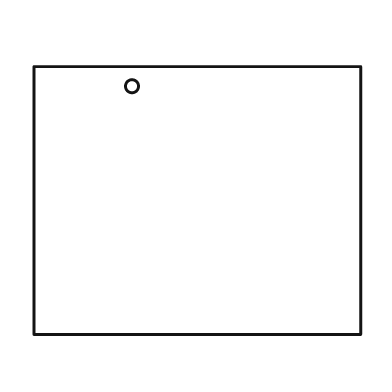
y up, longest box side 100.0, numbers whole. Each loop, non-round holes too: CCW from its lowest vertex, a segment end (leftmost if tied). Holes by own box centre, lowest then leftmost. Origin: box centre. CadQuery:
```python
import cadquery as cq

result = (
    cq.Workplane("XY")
    .moveTo(-50.0, -41.0)
    .lineTo(50.0, -41.0)
    .lineTo(50.0, 41.0)
    .lineTo(-50.0, 41.0)
    .close()
    .moveTo(-20.0, 35.0)
    .circle(2.0)
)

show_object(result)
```